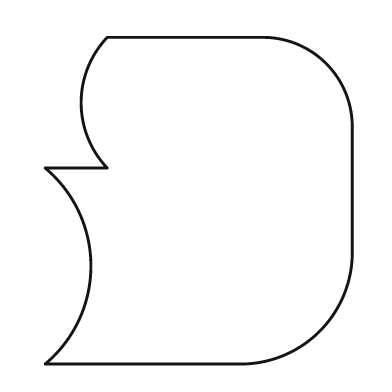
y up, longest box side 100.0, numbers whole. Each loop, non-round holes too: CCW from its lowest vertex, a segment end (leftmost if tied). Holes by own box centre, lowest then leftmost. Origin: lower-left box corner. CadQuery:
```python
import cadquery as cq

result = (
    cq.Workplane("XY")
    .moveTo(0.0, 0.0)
    .lineTo(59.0, 0.0)
    .threePointArc((84.0, 10.0), (94.0, 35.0))
    .lineTo(94.0, 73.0)
    .threePointArc((86.0, 92.0), (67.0, 100.0))
    .lineTo(19.0, 100.0)
    .threePointArc((11.0, 80.0), (19.0, 60.0))
    .lineTo(0.0, 60.0)
    .threePointArc((14.0, 30.0), (0.0, 0.0))
    .close()
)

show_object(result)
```